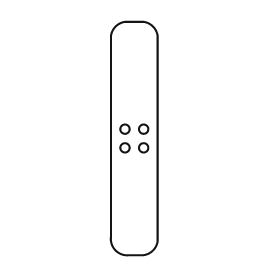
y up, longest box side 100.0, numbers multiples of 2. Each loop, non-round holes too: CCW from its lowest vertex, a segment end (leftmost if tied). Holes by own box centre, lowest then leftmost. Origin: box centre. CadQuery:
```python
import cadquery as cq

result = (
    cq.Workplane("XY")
    .moveTo(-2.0, -50.0)
    .lineTo(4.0, -50.0)
    .threePointArc((8.0, -48.0), (10.0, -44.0))
    .lineTo(10.0, 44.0)
    .threePointArc((8.0, 48.0), (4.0, 50.0))
    .lineTo(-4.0, 50.0)
    .threePointArc((-8.0, 48.0), (-10.0, 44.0))
    .lineTo(-10.0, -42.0)
    .threePointArc((-8.0, -48.0), (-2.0, -50.0))
    .close()
    .moveTo(-4.0, -4.0)
    .circle(2.0)
    .moveTo(4.0, -4.0)
    .circle(2.0)
    .moveTo(-4.0, 4.0)
    .circle(2.0)
    .moveTo(4.0, 4.0)
    .circle(2.0)
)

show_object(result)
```